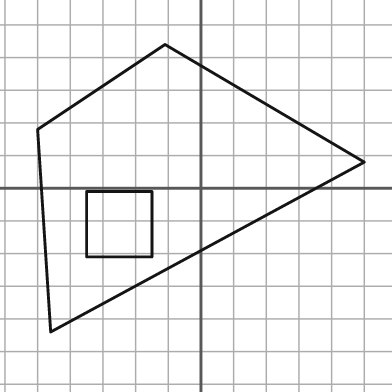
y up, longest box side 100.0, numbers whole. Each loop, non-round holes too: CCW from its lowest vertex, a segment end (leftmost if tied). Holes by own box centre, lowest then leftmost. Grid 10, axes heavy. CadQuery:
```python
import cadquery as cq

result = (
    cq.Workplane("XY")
    .moveTo(-46.0, -44.0)
    .lineTo(50.0, 8.0)
    .lineTo(-11.0, 44.0)
    .lineTo(-50.0, 18.0)
    .close()
    .moveTo(-35.0, -21.0)
    .lineTo(-15.0, -21.0)
    .lineTo(-15.0, -1.0)
    .lineTo(-35.0, -1.0)
    .close()
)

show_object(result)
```